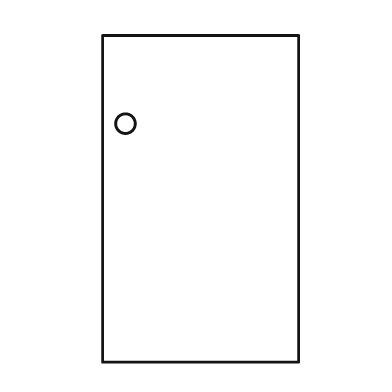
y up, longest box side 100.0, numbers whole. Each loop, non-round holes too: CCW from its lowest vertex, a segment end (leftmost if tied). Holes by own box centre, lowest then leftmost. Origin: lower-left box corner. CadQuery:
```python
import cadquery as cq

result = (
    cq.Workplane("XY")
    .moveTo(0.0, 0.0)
    .lineTo(60.0, 0.0)
    .lineTo(60.0, 100.0)
    .lineTo(0.0, 100.0)
    .close()
    .moveTo(7.0, 73.0)
    .circle(3.0)
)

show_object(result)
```